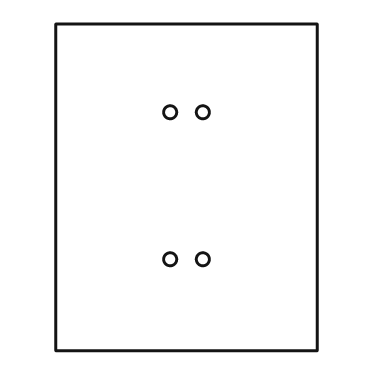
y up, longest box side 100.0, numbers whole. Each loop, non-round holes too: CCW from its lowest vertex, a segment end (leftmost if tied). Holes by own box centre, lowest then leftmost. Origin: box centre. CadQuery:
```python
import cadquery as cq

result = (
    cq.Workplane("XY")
    .moveTo(-40.0, -50.0)
    .lineTo(40.0, -50.0)
    .lineTo(40.0, 50.0)
    .lineTo(-40.0, 50.0)
    .close()
    .moveTo(-5.0, -22.0)
    .circle(2.0)
    .moveTo(5.0, -22.0)
    .circle(2.0)
    .moveTo(-5.0, 23.0)
    .circle(2.0)
    .moveTo(5.0, 23.0)
    .circle(2.0)
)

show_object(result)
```